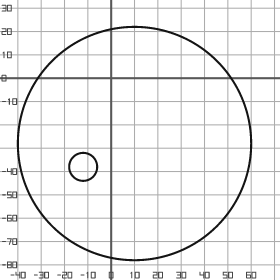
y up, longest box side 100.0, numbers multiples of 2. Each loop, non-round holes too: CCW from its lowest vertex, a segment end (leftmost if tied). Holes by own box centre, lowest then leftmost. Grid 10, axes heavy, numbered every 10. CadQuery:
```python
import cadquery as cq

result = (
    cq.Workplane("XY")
    .moveTo(10.0, -28.0)
    .circle(50.0)
    .moveTo(-12.0, -38.0)
    .circle(6.0)
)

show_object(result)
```